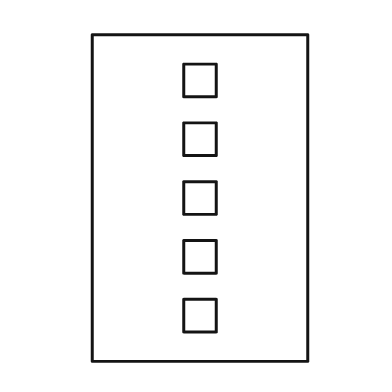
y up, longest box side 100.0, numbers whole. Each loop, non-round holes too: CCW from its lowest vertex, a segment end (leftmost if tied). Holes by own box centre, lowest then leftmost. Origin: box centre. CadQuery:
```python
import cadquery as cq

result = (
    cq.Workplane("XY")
    .moveTo(-33.0, -50.0)
    .lineTo(33.0, -50.0)
    .lineTo(33.0, 50.0)
    .lineTo(-33.0, 50.0)
    .close()
    .moveTo(-5.0, -41.0)
    .lineTo(5.0, -41.0)
    .lineTo(5.0, -31.0)
    .lineTo(-5.0, -31.0)
    .close()
    .moveTo(-5.0, -23.0)
    .lineTo(5.0, -23.0)
    .lineTo(5.0, -13.0)
    .lineTo(-5.0, -13.0)
    .close()
    .moveTo(-5.0, -5.0)
    .lineTo(5.0, -5.0)
    .lineTo(5.0, 5.0)
    .lineTo(-5.0, 5.0)
    .close()
    .moveTo(-5.0, 13.0)
    .lineTo(5.0, 13.0)
    .lineTo(5.0, 23.0)
    .lineTo(-5.0, 23.0)
    .close()
    .moveTo(-5.0, 31.0)
    .lineTo(5.0, 31.0)
    .lineTo(5.0, 41.0)
    .lineTo(-5.0, 41.0)
    .close()
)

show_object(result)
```